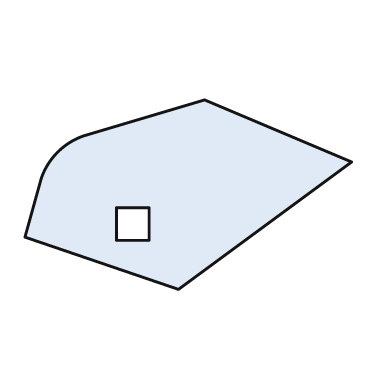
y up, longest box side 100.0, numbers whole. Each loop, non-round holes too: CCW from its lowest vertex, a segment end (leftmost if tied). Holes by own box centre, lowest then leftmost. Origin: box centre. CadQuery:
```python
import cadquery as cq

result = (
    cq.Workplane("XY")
    .moveTo(-3.0, -29.0)
    .lineTo(50.0, 10.0)
    .lineTo(5.0, 29.0)
    .lineTo(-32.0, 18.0)
    .threePointArc((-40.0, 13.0), (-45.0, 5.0))
    .lineTo(-50.0, -13.0)
    .close()
    .moveTo(-22.0, -14.0)
    .lineTo(-12.0, -14.0)
    .lineTo(-12.0, -4.0)
    .lineTo(-22.0, -4.0)
    .close()
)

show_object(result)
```